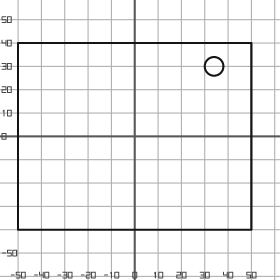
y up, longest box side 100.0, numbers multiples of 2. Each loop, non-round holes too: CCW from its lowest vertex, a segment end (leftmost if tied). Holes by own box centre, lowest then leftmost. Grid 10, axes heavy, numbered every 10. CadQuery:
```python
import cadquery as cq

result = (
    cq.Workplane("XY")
    .moveTo(-50.0, -40.0)
    .lineTo(50.0, -40.0)
    .lineTo(50.0, 40.0)
    .lineTo(-50.0, 40.0)
    .close()
    .moveTo(34.0, 30.0)
    .circle(4.0)
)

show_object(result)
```